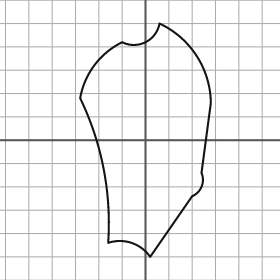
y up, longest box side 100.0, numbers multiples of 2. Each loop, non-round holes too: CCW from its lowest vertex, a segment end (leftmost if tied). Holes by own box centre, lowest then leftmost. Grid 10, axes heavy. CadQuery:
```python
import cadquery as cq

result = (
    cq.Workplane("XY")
    .moveTo(2.0, -50.0)
    .lineTo(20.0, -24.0)
    .threePointArc((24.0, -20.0), (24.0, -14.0))
    .lineTo(28.0, 16.0)
    .threePointArc((22.0, 36.0), (6.0, 50.0))
    .threePointArc((0.0, 42.0), (-10.0, 42.0))
    .threePointArc((-22.0, 32.0), (-28.0, 18.0))
    .threePointArc((-18.0, -12.0), (-16.0, -44.0))
    .threePointArc((-6.0, -44.0), (2.0, -50.0))
    .close()
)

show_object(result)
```